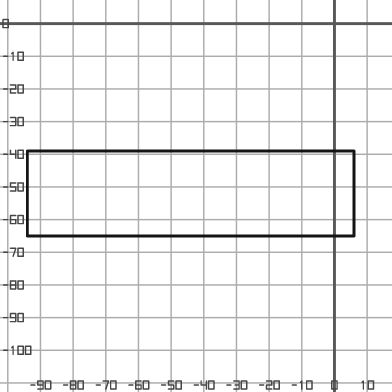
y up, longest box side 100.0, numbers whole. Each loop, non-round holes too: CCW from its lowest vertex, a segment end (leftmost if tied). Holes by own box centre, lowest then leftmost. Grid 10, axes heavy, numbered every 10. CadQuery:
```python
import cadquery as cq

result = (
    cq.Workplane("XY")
    .moveTo(-94.0, -65.0)
    .lineTo(6.0, -65.0)
    .lineTo(6.0, -39.0)
    .lineTo(-94.0, -39.0)
    .close()
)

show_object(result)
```